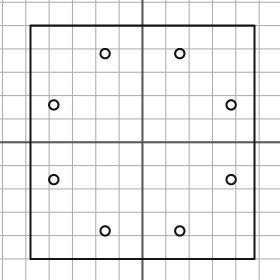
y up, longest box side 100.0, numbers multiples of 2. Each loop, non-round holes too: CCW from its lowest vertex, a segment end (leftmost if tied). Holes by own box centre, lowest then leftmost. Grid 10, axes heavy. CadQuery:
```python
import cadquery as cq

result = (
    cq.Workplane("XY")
    .moveTo(-48.0, -50.0)
    .lineTo(48.0, -50.0)
    .lineTo(48.0, 50.0)
    .lineTo(-48.0, 50.0)
    .close()
    .moveTo(-16.0, -38.0)
    .circle(2.0)
    .moveTo(16.0, -38.0)
    .circle(2.0)
    .moveTo(-38.0, -16.0)
    .circle(2.0)
    .moveTo(38.0, -16.0)
    .circle(2.0)
    .moveTo(-38.0, 16.0)
    .circle(2.0)
    .moveTo(38.0, 16.0)
    .circle(2.0)
    .moveTo(-16.0, 38.0)
    .circle(2.0)
    .moveTo(16.0, 38.0)
    .circle(2.0)
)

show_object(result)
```